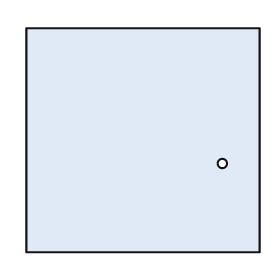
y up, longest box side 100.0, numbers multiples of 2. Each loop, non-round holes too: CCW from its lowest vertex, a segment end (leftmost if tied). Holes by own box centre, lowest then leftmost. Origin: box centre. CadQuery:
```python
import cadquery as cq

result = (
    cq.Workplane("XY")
    .moveTo(-50.0, -48.0)
    .lineTo(50.0, -48.0)
    .lineTo(50.0, 48.0)
    .lineTo(-50.0, 48.0)
    .close()
    .moveTo(34.0, -10.0)
    .circle(2.0)
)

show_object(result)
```